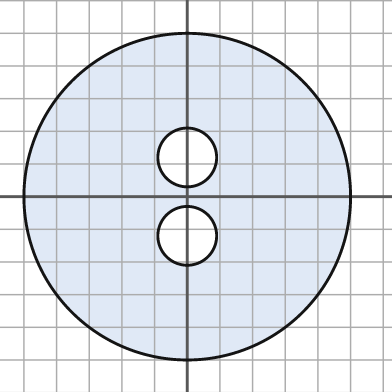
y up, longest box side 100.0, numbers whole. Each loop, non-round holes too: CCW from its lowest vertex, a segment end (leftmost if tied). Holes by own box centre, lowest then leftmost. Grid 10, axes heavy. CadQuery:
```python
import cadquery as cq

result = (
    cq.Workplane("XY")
    .moveTo(0.0, 0.0)
    .circle(50.0)
    .moveTo(0.0, -12.0)
    .circle(9.0)
    .moveTo(0.0, 12.0)
    .circle(9.0)
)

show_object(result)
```